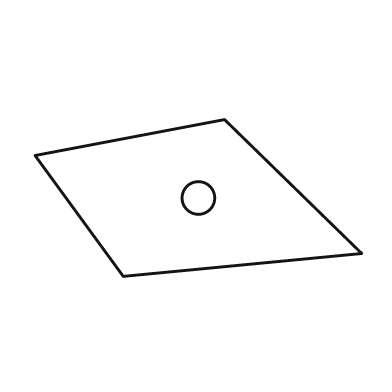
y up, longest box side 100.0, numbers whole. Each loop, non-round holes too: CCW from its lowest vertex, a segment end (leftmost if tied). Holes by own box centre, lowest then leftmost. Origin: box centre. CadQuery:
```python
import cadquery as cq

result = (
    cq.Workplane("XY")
    .moveTo(-23.0, -24.0)
    .lineTo(50.0, -17.0)
    .lineTo(8.0, 24.0)
    .lineTo(-50.0, 13.0)
    .close()
    .moveTo(0.0, 0.0)
    .circle(5.0)
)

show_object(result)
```